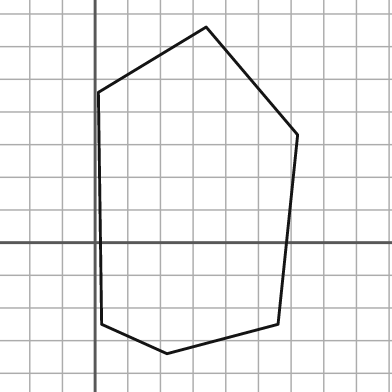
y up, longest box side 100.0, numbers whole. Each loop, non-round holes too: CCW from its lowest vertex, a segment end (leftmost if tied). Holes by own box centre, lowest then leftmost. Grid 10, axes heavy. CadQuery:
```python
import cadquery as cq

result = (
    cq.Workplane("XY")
    .moveTo(22.0, -34.0)
    .lineTo(56.0, -25.0)
    .lineTo(62.0, 33.0)
    .lineTo(34.0, 66.0)
    .lineTo(1.0, 46.0)
    .lineTo(2.0, -25.0)
    .close()
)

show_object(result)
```